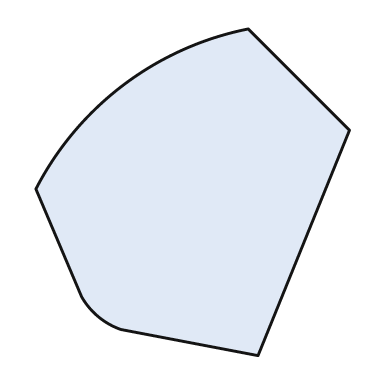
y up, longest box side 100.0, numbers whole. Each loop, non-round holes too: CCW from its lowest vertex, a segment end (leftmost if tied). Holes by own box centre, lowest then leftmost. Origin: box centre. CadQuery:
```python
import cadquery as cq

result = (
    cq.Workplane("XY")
    .moveTo(20.0, -50.0)
    .lineTo(48.0, 19.0)
    .lineTo(17.0, 50.0)
    .threePointArc((-21.0, 33.0), (-48.0, 1.0))
    .lineTo(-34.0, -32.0)
    .threePointArc((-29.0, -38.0), (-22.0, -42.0))
    .close()
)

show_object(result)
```